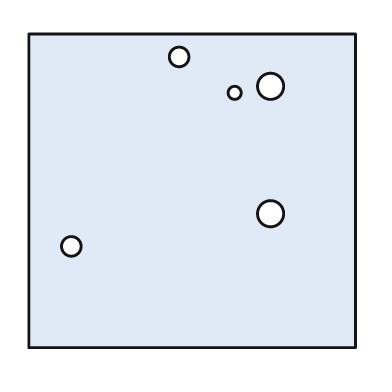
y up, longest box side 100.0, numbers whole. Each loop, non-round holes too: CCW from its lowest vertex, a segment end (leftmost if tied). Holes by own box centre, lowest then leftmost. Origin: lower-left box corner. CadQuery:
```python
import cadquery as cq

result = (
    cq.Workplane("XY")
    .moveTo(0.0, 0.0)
    .lineTo(100.0, 0.0)
    .lineTo(100.0, 96.0)
    .lineTo(0.0, 96.0)
    .close()
    .moveTo(13.0, 31.0)
    .circle(3.0)
    .moveTo(74.0, 41.0)
    .circle(4.0)
    .moveTo(63.0, 78.0)
    .circle(2.0)
    .moveTo(74.0, 80.0)
    .circle(4.0)
    .moveTo(46.0, 89.0)
    .circle(3.0)
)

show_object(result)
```